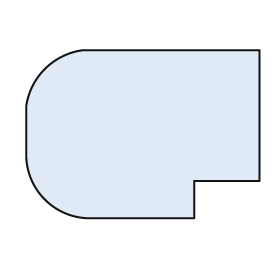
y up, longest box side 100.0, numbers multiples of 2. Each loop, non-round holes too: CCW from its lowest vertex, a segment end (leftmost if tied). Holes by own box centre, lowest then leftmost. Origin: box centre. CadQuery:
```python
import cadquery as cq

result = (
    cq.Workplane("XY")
    .moveTo(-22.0, -36.0)
    .lineTo(22.0, -36.0)
    .lineTo(22.0, -20.0)
    .lineTo(50.0, -20.0)
    .lineTo(50.0, 36.0)
    .lineTo(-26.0, 36.0)
    .threePointArc((-42.0, 28.0), (-50.0, 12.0))
    .lineTo(-50.0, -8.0)
    .threePointArc((-42.0, -28.0), (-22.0, -36.0))
    .close()
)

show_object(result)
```